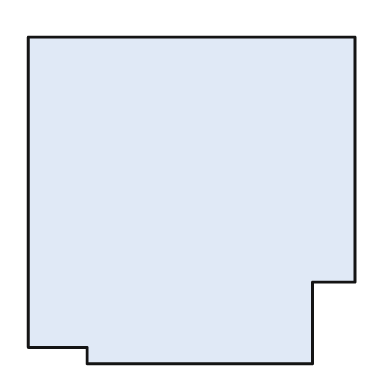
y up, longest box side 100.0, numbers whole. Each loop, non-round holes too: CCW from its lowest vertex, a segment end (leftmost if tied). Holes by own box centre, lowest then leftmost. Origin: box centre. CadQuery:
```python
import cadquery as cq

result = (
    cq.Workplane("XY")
    .moveTo(-32.0, -50.0)
    .lineTo(37.0, -50.0)
    .lineTo(37.0, -25.0)
    .lineTo(50.0, -25.0)
    .lineTo(50.0, 50.0)
    .lineTo(-50.0, 50.0)
    .lineTo(-50.0, -45.0)
    .lineTo(-32.0, -45.0)
    .close()
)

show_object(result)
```